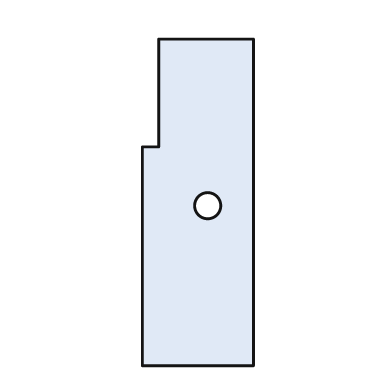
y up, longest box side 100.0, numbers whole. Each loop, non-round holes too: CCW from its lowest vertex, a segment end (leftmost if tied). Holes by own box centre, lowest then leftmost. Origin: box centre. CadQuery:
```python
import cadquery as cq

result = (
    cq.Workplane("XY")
    .moveTo(-17.0, -50.0)
    .lineTo(17.0, -50.0)
    .lineTo(17.0, 50.0)
    .lineTo(-12.0, 50.0)
    .lineTo(-12.0, 17.0)
    .lineTo(-17.0, 17.0)
    .close()
    .moveTo(3.0, -1.0)
    .circle(4.0)
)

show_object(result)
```